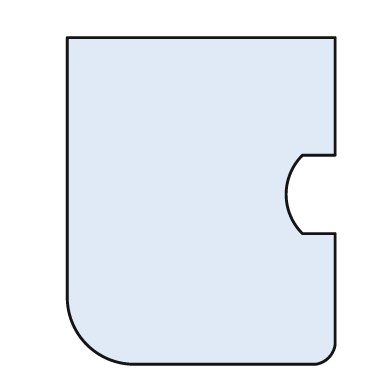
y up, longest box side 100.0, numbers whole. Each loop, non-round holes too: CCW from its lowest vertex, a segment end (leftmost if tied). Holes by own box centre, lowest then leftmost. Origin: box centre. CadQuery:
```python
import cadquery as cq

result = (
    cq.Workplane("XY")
    .moveTo(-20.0, -50.0)
    .lineTo(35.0, -50.0)
    .threePointArc((39.0, -48.0), (41.0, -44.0))
    .lineTo(41.0, -10.0)
    .lineTo(31.0, -10.0)
    .threePointArc((26.0, 2.0), (31.0, 14.0))
    .lineTo(41.0, 14.0)
    .lineTo(41.0, 50.0)
    .lineTo(-41.0, 50.0)
    .lineTo(-41.0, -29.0)
    .threePointArc((-35.0, -44.0), (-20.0, -50.0))
    .close()
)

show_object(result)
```